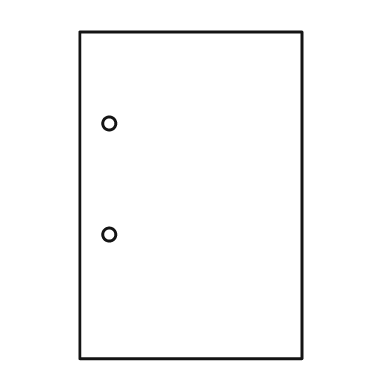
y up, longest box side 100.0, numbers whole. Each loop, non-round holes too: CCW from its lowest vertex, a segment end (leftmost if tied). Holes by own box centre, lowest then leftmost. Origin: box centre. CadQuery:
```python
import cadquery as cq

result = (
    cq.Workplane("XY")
    .moveTo(-34.0, -50.0)
    .lineTo(34.0, -50.0)
    .lineTo(34.0, 50.0)
    .lineTo(-34.0, 50.0)
    .close()
    .moveTo(-25.0, -12.0)
    .circle(2.0)
    .moveTo(-25.0, 22.0)
    .circle(2.0)
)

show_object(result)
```